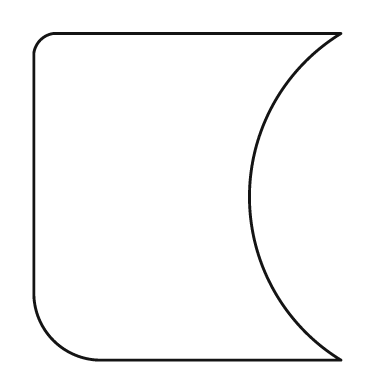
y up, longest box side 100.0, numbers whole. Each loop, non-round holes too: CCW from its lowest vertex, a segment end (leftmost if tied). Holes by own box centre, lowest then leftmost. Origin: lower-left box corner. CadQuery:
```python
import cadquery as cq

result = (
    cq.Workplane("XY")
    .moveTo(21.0, 0.0)
    .lineTo(94.0, 0.0)
    .threePointArc((66.0, 50.0), (94.0, 100.0))
    .lineTo(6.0, 100.0)
    .threePointArc((2.0, 98.0), (0.0, 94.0))
    .lineTo(0.0, 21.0)
    .threePointArc((6.0, 6.0), (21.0, 0.0))
    .close()
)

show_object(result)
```